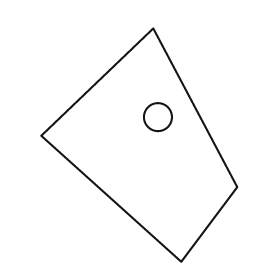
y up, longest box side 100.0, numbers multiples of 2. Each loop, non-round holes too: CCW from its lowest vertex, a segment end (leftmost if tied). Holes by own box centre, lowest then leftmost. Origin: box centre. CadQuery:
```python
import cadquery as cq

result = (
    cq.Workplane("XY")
    .moveTo(18.0, -50.0)
    .lineTo(42.0, -18.0)
    .lineTo(6.0, 50.0)
    .lineTo(-42.0, 4.0)
    .close()
    .moveTo(8.0, 12.0)
    .circle(6.0)
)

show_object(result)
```